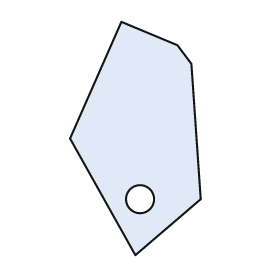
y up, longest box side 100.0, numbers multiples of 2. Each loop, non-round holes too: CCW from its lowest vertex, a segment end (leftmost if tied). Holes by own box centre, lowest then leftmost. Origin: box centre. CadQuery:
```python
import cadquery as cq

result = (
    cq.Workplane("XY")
    .moveTo(0.0, -50.0)
    .lineTo(28.0, -26.0)
    .lineTo(24.0, 32.0)
    .lineTo(18.0, 40.0)
    .lineTo(-6.0, 50.0)
    .lineTo(-28.0, 0.0)
    .close()
    .moveTo(2.0, -26.0)
    .circle(6.0)
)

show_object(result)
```